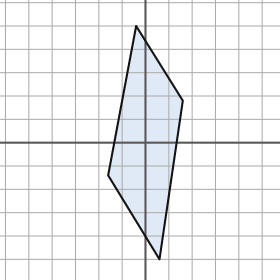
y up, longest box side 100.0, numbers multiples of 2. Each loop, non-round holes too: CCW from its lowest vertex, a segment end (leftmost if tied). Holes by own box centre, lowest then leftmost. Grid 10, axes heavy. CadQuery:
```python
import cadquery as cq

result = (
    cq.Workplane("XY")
    .moveTo(6.0, -50.0)
    .lineTo(16.0, 18.0)
    .lineTo(-4.0, 50.0)
    .lineTo(-16.0, -14.0)
    .close()
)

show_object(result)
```